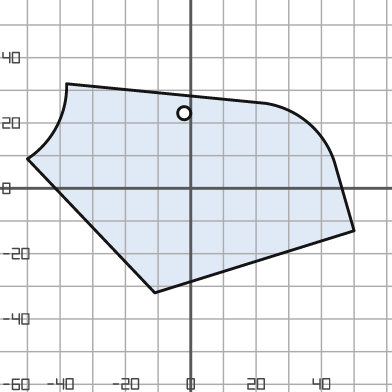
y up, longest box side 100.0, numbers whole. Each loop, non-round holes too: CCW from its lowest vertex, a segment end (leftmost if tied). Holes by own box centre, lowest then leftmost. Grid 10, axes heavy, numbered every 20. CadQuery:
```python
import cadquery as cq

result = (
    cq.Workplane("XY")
    .moveTo(-11.0, -32.0)
    .lineTo(50.0, -13.0)
    .lineTo(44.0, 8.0)
    .threePointArc((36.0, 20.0), (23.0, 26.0))
    .lineTo(-38.0, 32.0)
    .threePointArc((-41.0, 19.0), (-50.0, 9.0))
    .close()
    .moveTo(-2.0, 23.0)
    .circle(2.0)
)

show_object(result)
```